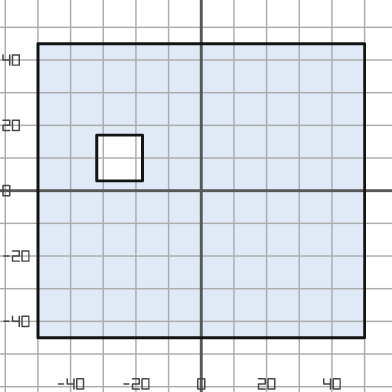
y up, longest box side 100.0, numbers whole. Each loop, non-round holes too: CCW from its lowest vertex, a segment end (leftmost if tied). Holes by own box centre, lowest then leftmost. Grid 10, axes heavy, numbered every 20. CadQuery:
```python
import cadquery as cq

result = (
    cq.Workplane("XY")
    .moveTo(-50.0, -45.0)
    .lineTo(50.0, -45.0)
    .lineTo(50.0, 45.0)
    .lineTo(-50.0, 45.0)
    .close()
    .moveTo(-32.0, 3.0)
    .lineTo(-18.0, 3.0)
    .lineTo(-18.0, 17.0)
    .lineTo(-32.0, 17.0)
    .close()
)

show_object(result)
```